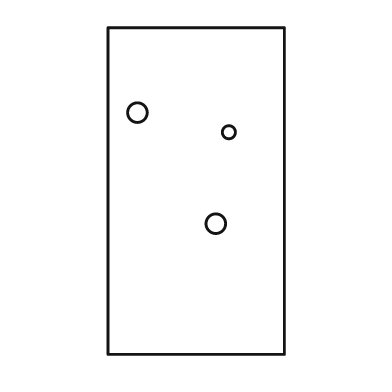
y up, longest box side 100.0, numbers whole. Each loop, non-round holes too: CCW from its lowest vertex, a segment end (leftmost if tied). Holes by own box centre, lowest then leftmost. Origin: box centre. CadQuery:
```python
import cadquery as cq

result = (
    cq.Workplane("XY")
    .moveTo(-27.0, -50.0)
    .lineTo(27.0, -50.0)
    .lineTo(27.0, 50.0)
    .lineTo(-27.0, 50.0)
    .close()
    .moveTo(6.0, -10.0)
    .circle(3.0)
    .moveTo(10.0, 18.0)
    .circle(2.0)
    .moveTo(-18.0, 24.0)
    .circle(3.0)
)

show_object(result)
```